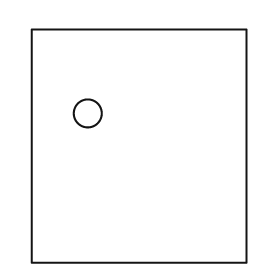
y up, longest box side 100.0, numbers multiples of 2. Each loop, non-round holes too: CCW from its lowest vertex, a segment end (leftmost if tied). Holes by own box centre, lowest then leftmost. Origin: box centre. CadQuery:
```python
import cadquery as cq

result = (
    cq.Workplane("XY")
    .moveTo(-46.0, -50.0)
    .lineTo(46.0, -50.0)
    .lineTo(46.0, 50.0)
    .lineTo(-46.0, 50.0)
    .close()
    .moveTo(-22.0, 14.0)
    .circle(6.0)
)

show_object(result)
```